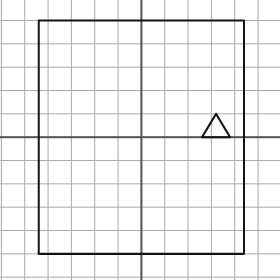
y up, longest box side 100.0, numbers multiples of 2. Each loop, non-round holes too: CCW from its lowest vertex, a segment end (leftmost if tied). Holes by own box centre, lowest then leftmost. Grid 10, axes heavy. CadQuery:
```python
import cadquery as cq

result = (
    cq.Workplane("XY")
    .moveTo(-44.0, -50.0)
    .lineTo(44.0, -50.0)
    .lineTo(44.0, 50.0)
    .lineTo(-44.0, 50.0)
    .close()
    .moveTo(26.0, 0.0)
    .lineTo(38.0, 0.0)
    .lineTo(32.0, 10.0)
    .close()
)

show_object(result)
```